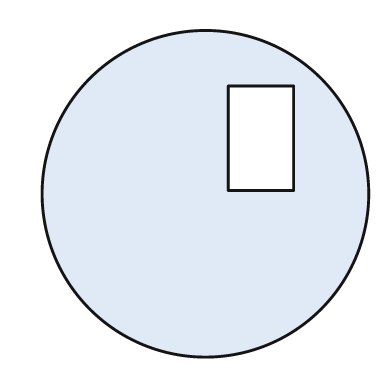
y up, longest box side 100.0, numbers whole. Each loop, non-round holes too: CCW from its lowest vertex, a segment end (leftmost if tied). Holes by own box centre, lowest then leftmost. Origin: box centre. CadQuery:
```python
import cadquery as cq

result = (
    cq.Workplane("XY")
    .moveTo(0.0, 0.0)
    .circle(50.0)
    .moveTo(7.0, 1.0)
    .lineTo(27.0, 1.0)
    .lineTo(27.0, 33.0)
    .lineTo(7.0, 33.0)
    .close()
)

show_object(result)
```